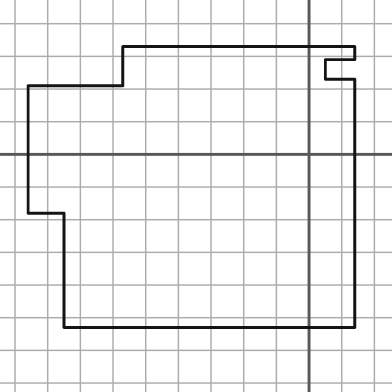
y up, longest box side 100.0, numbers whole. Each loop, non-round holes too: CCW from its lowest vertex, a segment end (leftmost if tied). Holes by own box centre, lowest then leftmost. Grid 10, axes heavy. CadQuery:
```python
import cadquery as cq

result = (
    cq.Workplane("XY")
    .moveTo(-75.0, -53.0)
    .lineTo(14.0, -53.0)
    .lineTo(14.0, 23.0)
    .lineTo(5.0, 23.0)
    .lineTo(5.0, 29.0)
    .lineTo(14.0, 29.0)
    .lineTo(14.0, 33.0)
    .lineTo(-57.0, 33.0)
    .lineTo(-57.0, 21.0)
    .lineTo(-86.0, 21.0)
    .lineTo(-86.0, -18.0)
    .lineTo(-75.0, -18.0)
    .close()
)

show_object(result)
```